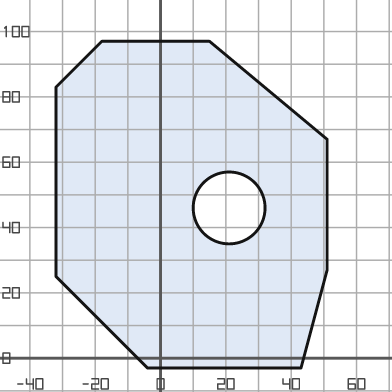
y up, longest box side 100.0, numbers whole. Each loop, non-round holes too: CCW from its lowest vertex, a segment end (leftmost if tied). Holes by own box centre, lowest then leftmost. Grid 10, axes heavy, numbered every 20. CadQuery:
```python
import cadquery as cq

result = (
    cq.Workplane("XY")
    .moveTo(-4.0, -3.0)
    .lineTo(43.0, -3.0)
    .lineTo(51.0, 27.0)
    .lineTo(51.0, 67.0)
    .lineTo(15.0, 97.0)
    .lineTo(-18.0, 97.0)
    .lineTo(-32.0, 83.0)
    .lineTo(-32.0, 25.0)
    .close()
    .moveTo(21.0, 46.0)
    .circle(11.0)
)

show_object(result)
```